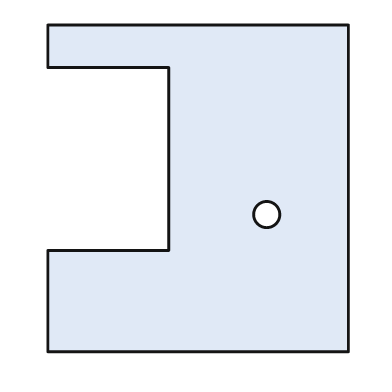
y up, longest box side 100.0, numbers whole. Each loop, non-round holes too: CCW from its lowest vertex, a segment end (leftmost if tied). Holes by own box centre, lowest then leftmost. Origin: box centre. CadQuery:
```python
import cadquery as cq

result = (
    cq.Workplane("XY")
    .moveTo(-46.0, -50.0)
    .lineTo(46.0, -50.0)
    .lineTo(46.0, 50.0)
    .lineTo(-46.0, 50.0)
    .lineTo(-46.0, 37.0)
    .lineTo(-9.0, 37.0)
    .lineTo(-9.0, -19.0)
    .lineTo(-46.0, -19.0)
    .close()
    .moveTo(21.0, -8.0)
    .circle(4.0)
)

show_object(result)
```